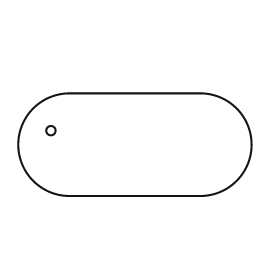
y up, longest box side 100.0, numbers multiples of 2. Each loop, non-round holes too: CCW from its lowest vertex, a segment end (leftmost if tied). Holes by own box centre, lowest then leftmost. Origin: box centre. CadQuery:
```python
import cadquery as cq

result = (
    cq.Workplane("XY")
    .moveTo(-28.0, -22.0)
    .lineTo(28.0, -22.0)
    .threePointArc((50.0, 0.0), (28.0, 22.0))
    .lineTo(-28.0, 22.0)
    .threePointArc((-50.0, 0.0), (-28.0, -22.0))
    .close()
    .moveTo(-36.0, 6.0)
    .circle(2.0)
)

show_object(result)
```